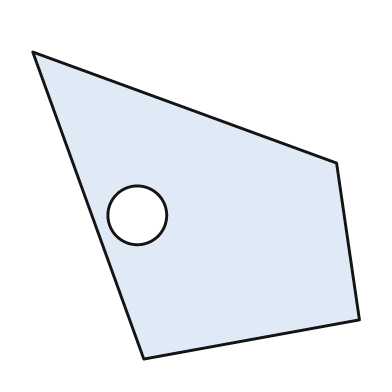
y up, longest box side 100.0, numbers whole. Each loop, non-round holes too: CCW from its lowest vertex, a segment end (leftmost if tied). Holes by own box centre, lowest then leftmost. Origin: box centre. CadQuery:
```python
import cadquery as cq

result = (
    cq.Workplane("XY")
    .moveTo(-16.0, -47.0)
    .lineTo(50.0, -35.0)
    .lineTo(43.0, 13.0)
    .lineTo(-50.0, 47.0)
    .close()
    .moveTo(-18.0, -3.0)
    .circle(9.0)
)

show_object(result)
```